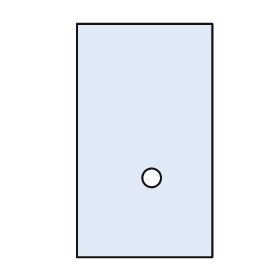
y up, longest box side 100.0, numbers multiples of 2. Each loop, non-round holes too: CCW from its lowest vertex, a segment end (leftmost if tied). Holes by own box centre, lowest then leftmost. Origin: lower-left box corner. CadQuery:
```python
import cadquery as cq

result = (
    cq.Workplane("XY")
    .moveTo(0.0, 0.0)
    .lineTo(58.0, 0.0)
    .lineTo(58.0, 100.0)
    .lineTo(0.0, 100.0)
    .close()
    .moveTo(32.0, 34.0)
    .circle(4.0)
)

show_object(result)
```